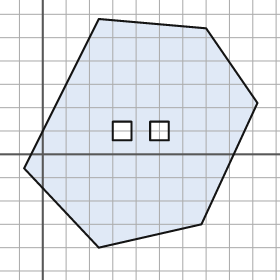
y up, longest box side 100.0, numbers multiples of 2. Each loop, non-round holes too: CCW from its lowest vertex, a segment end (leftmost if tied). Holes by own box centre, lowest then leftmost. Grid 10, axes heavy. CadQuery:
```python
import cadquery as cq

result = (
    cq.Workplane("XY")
    .moveTo(24.0, -40.0)
    .lineTo(68.0, -30.0)
    .lineTo(92.0, 22.0)
    .lineTo(70.0, 54.0)
    .lineTo(24.0, 58.0)
    .lineTo(-8.0, -6.0)
    .close()
    .moveTo(30.0, 6.0)
    .lineTo(38.0, 6.0)
    .lineTo(38.0, 14.0)
    .lineTo(30.0, 14.0)
    .close()
    .moveTo(46.0, 6.0)
    .lineTo(54.0, 6.0)
    .lineTo(54.0, 14.0)
    .lineTo(46.0, 14.0)
    .close()
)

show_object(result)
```